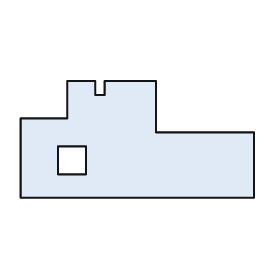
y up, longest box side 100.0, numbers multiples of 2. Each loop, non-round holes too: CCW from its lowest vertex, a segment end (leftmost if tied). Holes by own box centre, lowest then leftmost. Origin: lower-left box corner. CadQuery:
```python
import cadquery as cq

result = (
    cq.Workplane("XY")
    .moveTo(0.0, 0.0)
    .lineTo(100.0, 0.0)
    .lineTo(100.0, 28.0)
    .lineTo(58.0, 28.0)
    .lineTo(58.0, 50.0)
    .lineTo(36.0, 50.0)
    .lineTo(36.0, 44.0)
    .lineTo(32.0, 44.0)
    .lineTo(32.0, 50.0)
    .lineTo(20.0, 50.0)
    .lineTo(20.0, 34.0)
    .lineTo(0.0, 34.0)
    .close()
    .moveTo(16.0, 10.0)
    .lineTo(28.0, 10.0)
    .lineTo(28.0, 22.0)
    .lineTo(16.0, 22.0)
    .close()
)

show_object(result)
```